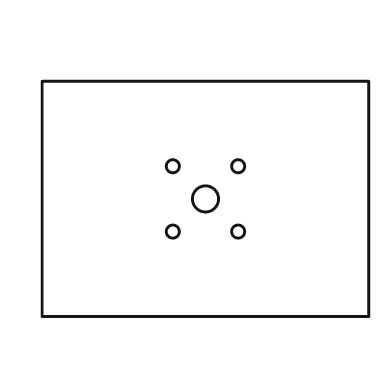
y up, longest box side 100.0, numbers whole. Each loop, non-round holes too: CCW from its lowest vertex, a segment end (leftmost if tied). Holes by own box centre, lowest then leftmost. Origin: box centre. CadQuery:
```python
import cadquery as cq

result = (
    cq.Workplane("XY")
    .moveTo(-50.0, -36.0)
    .lineTo(50.0, -36.0)
    .lineTo(50.0, 36.0)
    .lineTo(-50.0, 36.0)
    .close()
    .moveTo(-10.0, -10.0)
    .circle(2.0)
    .moveTo(10.0, -10.0)
    .circle(2.0)
    .moveTo(0.0, 0.0)
    .circle(4.0)
    .moveTo(-10.0, 10.0)
    .circle(2.0)
    .moveTo(10.0, 10.0)
    .circle(2.0)
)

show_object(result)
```